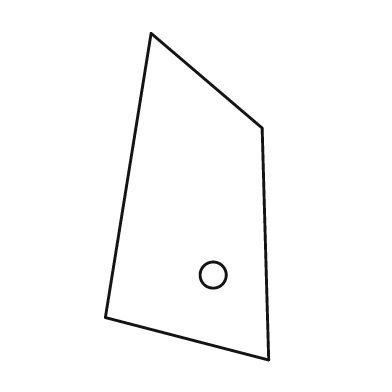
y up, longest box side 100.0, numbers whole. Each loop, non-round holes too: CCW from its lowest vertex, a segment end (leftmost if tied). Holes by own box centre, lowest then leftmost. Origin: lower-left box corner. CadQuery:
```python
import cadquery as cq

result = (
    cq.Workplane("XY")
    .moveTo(50.0, 0.0)
    .lineTo(48.0, 71.0)
    .lineTo(14.0, 100.0)
    .lineTo(0.0, 13.0)
    .close()
    .moveTo(33.0, 26.0)
    .circle(4.0)
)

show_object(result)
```